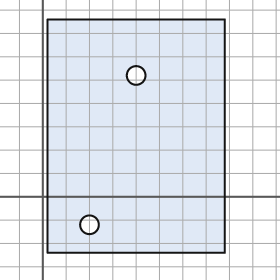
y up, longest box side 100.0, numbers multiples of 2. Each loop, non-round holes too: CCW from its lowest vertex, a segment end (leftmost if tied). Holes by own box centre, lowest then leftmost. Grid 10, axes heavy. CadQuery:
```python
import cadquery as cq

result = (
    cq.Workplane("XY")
    .moveTo(2.0, -24.0)
    .lineTo(78.0, -24.0)
    .lineTo(78.0, 76.0)
    .lineTo(2.0, 76.0)
    .close()
    .moveTo(20.0, -12.0)
    .circle(4.0)
    .moveTo(40.0, 52.0)
    .circle(4.0)
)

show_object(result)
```